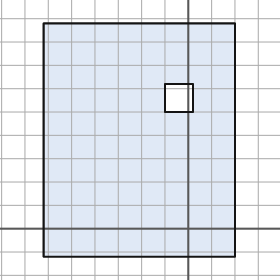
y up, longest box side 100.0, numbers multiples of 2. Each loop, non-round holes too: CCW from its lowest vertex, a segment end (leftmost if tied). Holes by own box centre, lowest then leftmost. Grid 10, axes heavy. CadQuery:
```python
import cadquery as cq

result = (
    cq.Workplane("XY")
    .moveTo(-62.0, -12.0)
    .lineTo(20.0, -12.0)
    .lineTo(20.0, 88.0)
    .lineTo(-62.0, 88.0)
    .close()
    .moveTo(-10.0, 50.0)
    .lineTo(2.0, 50.0)
    .lineTo(2.0, 62.0)
    .lineTo(-10.0, 62.0)
    .close()
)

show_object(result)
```